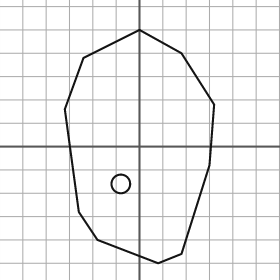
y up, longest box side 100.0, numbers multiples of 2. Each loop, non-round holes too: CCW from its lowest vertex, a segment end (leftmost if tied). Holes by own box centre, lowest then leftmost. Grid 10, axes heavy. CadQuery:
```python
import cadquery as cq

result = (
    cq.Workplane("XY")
    .moveTo(8.0, -50.0)
    .lineTo(18.0, -46.0)
    .lineTo(30.0, -8.0)
    .lineTo(32.0, 18.0)
    .lineTo(18.0, 40.0)
    .lineTo(0.0, 50.0)
    .lineTo(-24.0, 38.0)
    .lineTo(-32.0, 16.0)
    .lineTo(-26.0, -28.0)
    .lineTo(-18.0, -40.0)
    .close()
    .moveTo(-8.0, -16.0)
    .circle(4.0)
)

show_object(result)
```